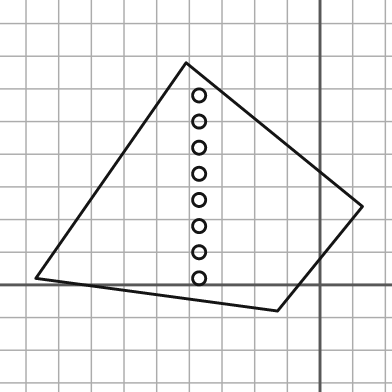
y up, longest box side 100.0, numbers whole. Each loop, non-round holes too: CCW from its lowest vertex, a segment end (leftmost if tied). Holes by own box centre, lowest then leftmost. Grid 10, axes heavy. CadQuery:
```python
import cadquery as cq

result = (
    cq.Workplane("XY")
    .moveTo(-13.0, -8.0)
    .lineTo(13.0, 24.0)
    .lineTo(-41.0, 68.0)
    .lineTo(-87.0, 2.0)
    .close()
    .moveTo(-37.0, 2.0)
    .circle(2.0)
    .moveTo(-37.0, 10.0)
    .circle(2.0)
    .moveTo(-37.0, 18.0)
    .circle(2.0)
    .moveTo(-37.0, 26.0)
    .circle(2.0)
    .moveTo(-37.0, 34.0)
    .circle(2.0)
    .moveTo(-37.0, 42.0)
    .circle(2.0)
    .moveTo(-37.0, 50.0)
    .circle(2.0)
    .moveTo(-37.0, 58.0)
    .circle(2.0)
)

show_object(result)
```